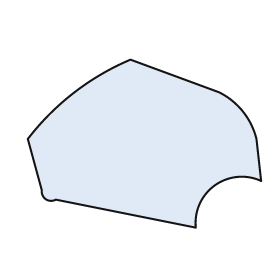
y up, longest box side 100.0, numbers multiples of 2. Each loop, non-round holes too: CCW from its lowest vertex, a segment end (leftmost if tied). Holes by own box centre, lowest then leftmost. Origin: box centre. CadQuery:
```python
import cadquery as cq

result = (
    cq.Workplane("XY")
    .moveTo(22.0, -36.0)
    .threePointArc((30.0, -18.0), (50.0, -16.0))
    .lineTo(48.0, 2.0)
    .threePointArc((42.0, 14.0), (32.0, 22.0))
    .lineTo(-6.0, 36.0)
    .threePointArc((-30.0, 22.0), (-50.0, 2.0))
    .lineTo(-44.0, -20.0)
    .threePointArc((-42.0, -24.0), (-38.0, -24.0))
    .close()
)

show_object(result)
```